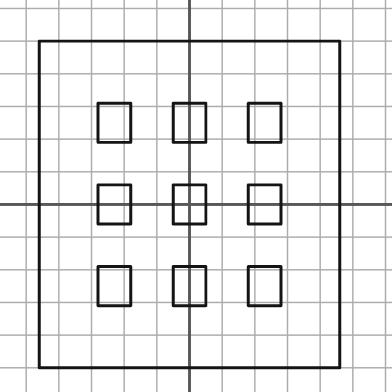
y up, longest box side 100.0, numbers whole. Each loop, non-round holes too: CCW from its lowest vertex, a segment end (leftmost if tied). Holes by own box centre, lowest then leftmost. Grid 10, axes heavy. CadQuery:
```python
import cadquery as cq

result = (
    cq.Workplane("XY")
    .moveTo(-46.0, -50.0)
    .lineTo(46.0, -50.0)
    .lineTo(46.0, 50.0)
    .lineTo(-46.0, 50.0)
    .close()
    .moveTo(-28.0, -31.0)
    .lineTo(-18.0, -31.0)
    .lineTo(-18.0, -19.0)
    .lineTo(-28.0, -19.0)
    .close()
    .moveTo(-5.0, -31.0)
    .lineTo(5.0, -31.0)
    .lineTo(5.0, -19.0)
    .lineTo(-5.0, -19.0)
    .close()
    .moveTo(18.0, -31.0)
    .lineTo(28.0, -31.0)
    .lineTo(28.0, -19.0)
    .lineTo(18.0, -19.0)
    .close()
    .moveTo(-28.0, -6.0)
    .lineTo(-18.0, -6.0)
    .lineTo(-18.0, 6.0)
    .lineTo(-28.0, 6.0)
    .close()
    .moveTo(-5.0, -6.0)
    .lineTo(5.0, -6.0)
    .lineTo(5.0, 6.0)
    .lineTo(-5.0, 6.0)
    .close()
    .moveTo(18.0, -6.0)
    .lineTo(28.0, -6.0)
    .lineTo(28.0, 6.0)
    .lineTo(18.0, 6.0)
    .close()
    .moveTo(-28.0, 19.0)
    .lineTo(-18.0, 19.0)
    .lineTo(-18.0, 31.0)
    .lineTo(-28.0, 31.0)
    .close()
    .moveTo(-5.0, 19.0)
    .lineTo(5.0, 19.0)
    .lineTo(5.0, 31.0)
    .lineTo(-5.0, 31.0)
    .close()
    .moveTo(18.0, 19.0)
    .lineTo(28.0, 19.0)
    .lineTo(28.0, 31.0)
    .lineTo(18.0, 31.0)
    .close()
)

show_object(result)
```